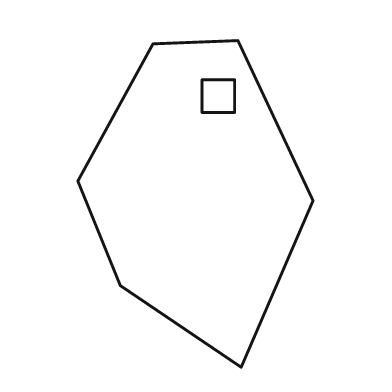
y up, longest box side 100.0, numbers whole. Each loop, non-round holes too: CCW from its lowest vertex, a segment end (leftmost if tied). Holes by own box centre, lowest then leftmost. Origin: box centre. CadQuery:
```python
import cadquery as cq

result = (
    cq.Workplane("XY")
    .moveTo(14.0, -50.0)
    .lineTo(36.0, 1.0)
    .lineTo(13.0, 50.0)
    .lineTo(-13.0, 49.0)
    .lineTo(-36.0, 7.0)
    .lineTo(-23.0, -25.0)
    .close()
    .moveTo(2.0, 28.0)
    .lineTo(12.0, 28.0)
    .lineTo(12.0, 38.0)
    .lineTo(2.0, 38.0)
    .close()
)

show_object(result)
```